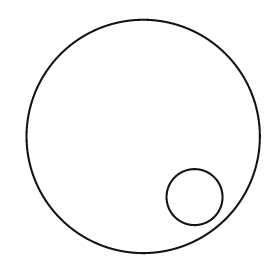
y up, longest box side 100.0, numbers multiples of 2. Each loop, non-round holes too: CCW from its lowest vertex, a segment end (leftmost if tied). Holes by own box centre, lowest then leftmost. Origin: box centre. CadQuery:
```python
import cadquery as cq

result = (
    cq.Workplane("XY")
    .moveTo(0.0, 0.0)
    .circle(50.0)
    .moveTo(22.0, -26.0)
    .circle(12.0)
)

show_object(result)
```